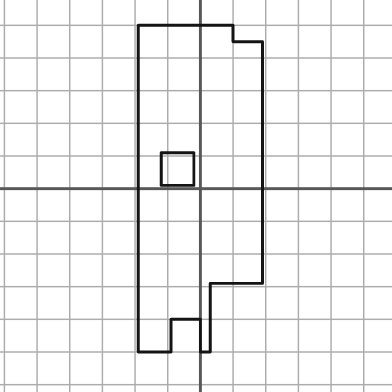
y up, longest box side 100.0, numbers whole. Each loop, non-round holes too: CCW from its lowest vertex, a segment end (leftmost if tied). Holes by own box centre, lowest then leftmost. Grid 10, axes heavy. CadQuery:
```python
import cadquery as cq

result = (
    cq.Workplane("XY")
    .moveTo(-19.0, -50.0)
    .lineTo(-9.0, -50.0)
    .lineTo(-9.0, -40.0)
    .lineTo(0.0, -40.0)
    .lineTo(0.0, -50.0)
    .lineTo(3.0, -50.0)
    .lineTo(3.0, -29.0)
    .lineTo(19.0, -29.0)
    .lineTo(19.0, 45.0)
    .lineTo(10.0, 45.0)
    .lineTo(10.0, 50.0)
    .lineTo(-19.0, 50.0)
    .close()
    .moveTo(-12.0, 1.0)
    .lineTo(-2.0, 1.0)
    .lineTo(-2.0, 11.0)
    .lineTo(-12.0, 11.0)
    .close()
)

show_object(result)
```